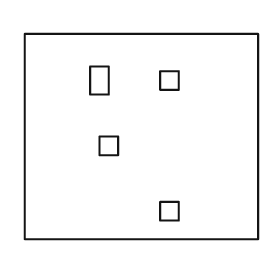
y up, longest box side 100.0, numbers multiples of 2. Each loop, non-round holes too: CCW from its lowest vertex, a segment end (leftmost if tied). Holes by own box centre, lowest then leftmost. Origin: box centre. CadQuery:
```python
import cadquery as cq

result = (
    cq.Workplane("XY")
    .moveTo(-50.0, -44.0)
    .lineTo(50.0, -44.0)
    .lineTo(50.0, 44.0)
    .lineTo(-50.0, 44.0)
    .close()
    .moveTo(8.0, -36.0)
    .lineTo(16.0, -36.0)
    .lineTo(16.0, -28.0)
    .lineTo(8.0, -28.0)
    .close()
    .moveTo(-18.0, -8.0)
    .lineTo(-10.0, -8.0)
    .lineTo(-10.0, 0.0)
    .lineTo(-18.0, 0.0)
    .close()
    .moveTo(-22.0, 18.0)
    .lineTo(-14.0, 18.0)
    .lineTo(-14.0, 30.0)
    .lineTo(-22.0, 30.0)
    .close()
    .moveTo(8.0, 20.0)
    .lineTo(16.0, 20.0)
    .lineTo(16.0, 28.0)
    .lineTo(8.0, 28.0)
    .close()
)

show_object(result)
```